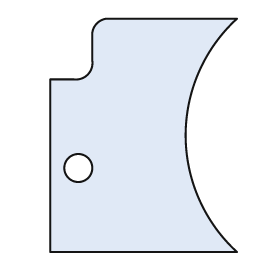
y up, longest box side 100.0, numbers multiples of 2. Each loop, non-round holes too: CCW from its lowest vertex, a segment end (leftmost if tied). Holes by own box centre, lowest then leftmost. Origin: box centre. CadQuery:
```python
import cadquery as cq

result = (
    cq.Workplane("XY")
    .moveTo(-40.0, -50.0)
    .lineTo(40.0, -50.0)
    .threePointArc((18.0, 0.0), (40.0, 50.0))
    .lineTo(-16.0, 50.0)
    .threePointArc((-20.0, 48.0), (-22.0, 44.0))
    .lineTo(-22.0, 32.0)
    .threePointArc((-24.0, 26.0), (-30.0, 24.0))
    .lineTo(-40.0, 24.0)
    .close()
    .moveTo(-28.0, -14.0)
    .circle(6.0)
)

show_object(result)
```